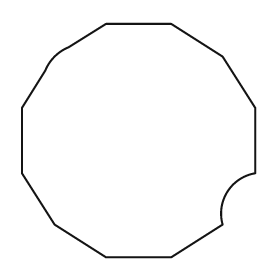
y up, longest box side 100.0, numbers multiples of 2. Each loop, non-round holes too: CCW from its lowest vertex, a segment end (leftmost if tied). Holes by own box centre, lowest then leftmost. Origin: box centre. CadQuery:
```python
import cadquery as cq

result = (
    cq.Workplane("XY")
    .moveTo(-14.0, -50.0)
    .lineTo(14.0, -50.0)
    .lineTo(36.0, -36.0)
    .threePointArc((38.0, -22.0), (50.0, -14.0))
    .lineTo(50.0, 14.0)
    .lineTo(36.0, 36.0)
    .lineTo(14.0, 50.0)
    .lineTo(-14.0, 50.0)
    .lineTo(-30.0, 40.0)
    .threePointArc((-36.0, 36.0), (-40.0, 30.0))
    .lineTo(-50.0, 14.0)
    .lineTo(-50.0, -14.0)
    .lineTo(-36.0, -36.0)
    .close()
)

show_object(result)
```